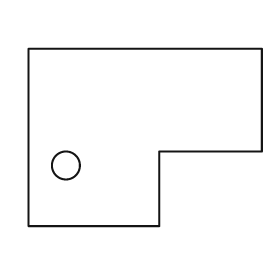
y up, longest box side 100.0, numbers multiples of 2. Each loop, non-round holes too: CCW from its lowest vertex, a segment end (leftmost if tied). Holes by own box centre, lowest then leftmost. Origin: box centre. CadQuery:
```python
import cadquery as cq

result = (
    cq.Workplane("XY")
    .moveTo(-50.0, -38.0)
    .lineTo(6.0, -38.0)
    .lineTo(6.0, -6.0)
    .lineTo(50.0, -6.0)
    .lineTo(50.0, 38.0)
    .lineTo(-50.0, 38.0)
    .close()
    .moveTo(-34.0, -12.0)
    .circle(6.0)
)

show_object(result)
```